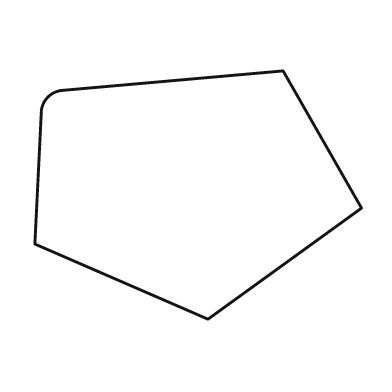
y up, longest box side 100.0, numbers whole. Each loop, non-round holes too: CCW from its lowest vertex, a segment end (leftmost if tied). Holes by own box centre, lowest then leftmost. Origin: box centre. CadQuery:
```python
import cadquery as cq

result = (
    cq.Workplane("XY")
    .moveTo(3.0, -38.0)
    .lineTo(50.0, -4.0)
    .lineTo(26.0, 38.0)
    .lineTo(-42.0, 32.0)
    .threePointArc((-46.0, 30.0), (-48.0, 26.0))
    .lineTo(-50.0, -15.0)
    .close()
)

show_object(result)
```